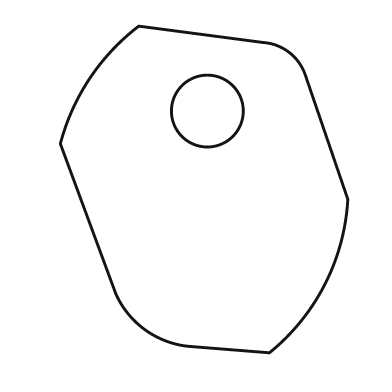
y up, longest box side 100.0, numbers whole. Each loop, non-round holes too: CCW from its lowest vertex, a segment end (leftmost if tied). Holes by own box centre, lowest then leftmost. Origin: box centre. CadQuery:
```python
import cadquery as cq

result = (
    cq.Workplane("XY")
    .moveTo(20.0, -50.0)
    .threePointArc((37.0, -29.0), (44.0, -3.0))
    .lineTo(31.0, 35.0)
    .threePointArc((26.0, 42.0), (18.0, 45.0))
    .lineTo(-20.0, 50.0)
    .threePointArc((-35.0, 34.0), (-44.0, 14.0))
    .lineTo(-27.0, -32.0)
    .threePointArc((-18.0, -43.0), (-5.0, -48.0))
    .close()
    .moveTo(1.0, 24.0)
    .circle(11.0)
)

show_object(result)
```